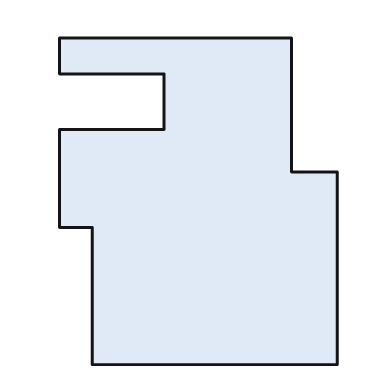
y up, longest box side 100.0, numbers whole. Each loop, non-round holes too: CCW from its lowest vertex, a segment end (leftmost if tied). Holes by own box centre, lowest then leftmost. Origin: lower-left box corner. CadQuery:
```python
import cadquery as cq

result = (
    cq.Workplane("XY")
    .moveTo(10.0, 0.0)
    .lineTo(85.0, 0.0)
    .lineTo(85.0, 59.0)
    .lineTo(71.0, 59.0)
    .lineTo(71.0, 100.0)
    .lineTo(0.0, 100.0)
    .lineTo(0.0, 89.0)
    .lineTo(32.0, 89.0)
    .lineTo(32.0, 72.0)
    .lineTo(0.0, 72.0)
    .lineTo(0.0, 42.0)
    .lineTo(10.0, 42.0)
    .close()
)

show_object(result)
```